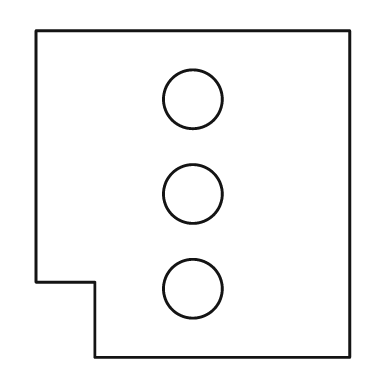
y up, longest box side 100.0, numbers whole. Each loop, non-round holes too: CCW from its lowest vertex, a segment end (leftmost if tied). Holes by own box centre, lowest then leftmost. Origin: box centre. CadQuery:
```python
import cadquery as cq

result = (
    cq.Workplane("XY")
    .moveTo(-30.0, -50.0)
    .lineTo(48.0, -50.0)
    .lineTo(48.0, 50.0)
    .lineTo(-48.0, 50.0)
    .lineTo(-48.0, -27.0)
    .lineTo(-30.0, -27.0)
    .close()
    .moveTo(0.0, -29.0)
    .circle(9.0)
    .moveTo(0.0, 0.0)
    .circle(9.0)
    .moveTo(0.0, 29.0)
    .circle(9.0)
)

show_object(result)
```